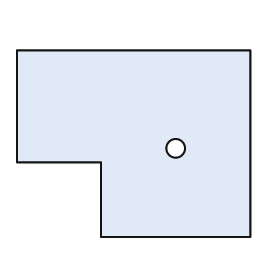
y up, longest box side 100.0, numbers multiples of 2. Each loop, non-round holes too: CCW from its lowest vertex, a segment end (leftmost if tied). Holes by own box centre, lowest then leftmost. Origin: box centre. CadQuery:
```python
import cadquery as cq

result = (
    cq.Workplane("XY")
    .moveTo(-14.0, -40.0)
    .lineTo(50.0, -40.0)
    .lineTo(50.0, 40.0)
    .lineTo(-50.0, 40.0)
    .lineTo(-50.0, -8.0)
    .lineTo(-14.0, -8.0)
    .close()
    .moveTo(18.0, -2.0)
    .circle(4.0)
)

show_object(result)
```